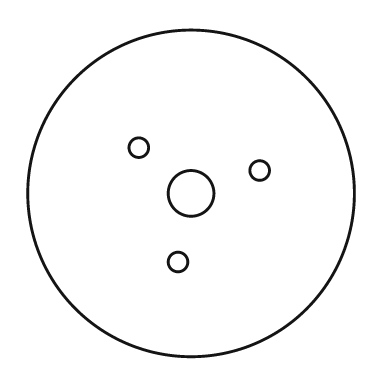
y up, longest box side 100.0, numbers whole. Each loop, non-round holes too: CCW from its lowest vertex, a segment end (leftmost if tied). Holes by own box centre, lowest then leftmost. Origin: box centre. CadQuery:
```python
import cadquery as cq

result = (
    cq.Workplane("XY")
    .moveTo(0.0, 0.0)
    .circle(50.0)
    .moveTo(-4.0, -21.0)
    .circle(3.0)
    .moveTo(0.0, 0.0)
    .circle(7.0)
    .moveTo(21.0, 7.0)
    .circle(3.0)
    .moveTo(-16.0, 14.0)
    .circle(3.0)
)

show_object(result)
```